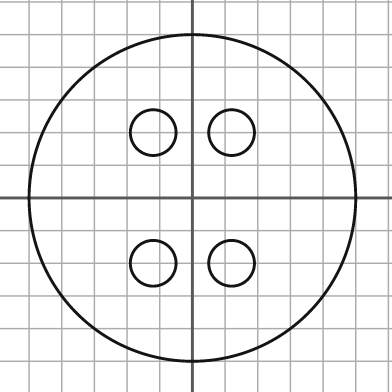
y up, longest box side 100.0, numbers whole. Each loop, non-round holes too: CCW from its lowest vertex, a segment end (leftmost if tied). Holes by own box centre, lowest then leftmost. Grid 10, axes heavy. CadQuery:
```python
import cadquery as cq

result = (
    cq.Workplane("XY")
    .moveTo(0.0, 0.0)
    .circle(50.0)
    .moveTo(-12.0, -20.0)
    .circle(7.0)
    .moveTo(12.0, -20.0)
    .circle(7.0)
    .moveTo(-12.0, 20.0)
    .circle(7.0)
    .moveTo(12.0, 20.0)
    .circle(7.0)
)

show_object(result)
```